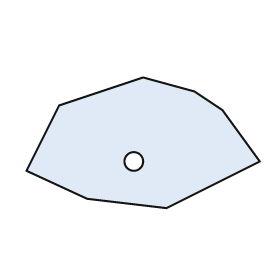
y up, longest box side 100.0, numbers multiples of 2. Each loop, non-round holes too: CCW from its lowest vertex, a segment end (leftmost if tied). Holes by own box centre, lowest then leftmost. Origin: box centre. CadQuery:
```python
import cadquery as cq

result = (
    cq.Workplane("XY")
    .moveTo(10.0, -28.0)
    .lineTo(50.0, -8.0)
    .lineTo(34.0, 14.0)
    .lineTo(22.0, 22.0)
    .lineTo(0.0, 28.0)
    .lineTo(-36.0, 16.0)
    .lineTo(-50.0, -12.0)
    .lineTo(-24.0, -24.0)
    .close()
    .moveTo(-4.0, -8.0)
    .circle(4.0)
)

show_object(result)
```